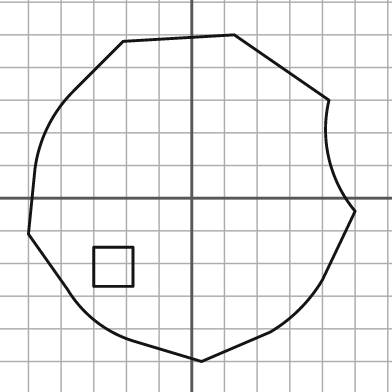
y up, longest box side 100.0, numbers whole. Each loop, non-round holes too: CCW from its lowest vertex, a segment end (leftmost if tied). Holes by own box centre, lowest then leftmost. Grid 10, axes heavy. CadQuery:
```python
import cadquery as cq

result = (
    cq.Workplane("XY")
    .moveTo(3.0, -50.0)
    .lineTo(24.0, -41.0)
    .threePointArc((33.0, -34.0), (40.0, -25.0))
    .lineTo(50.0, -4.0)
    .threePointArc((42.0, 12.0), (42.0, 30.0))
    .lineTo(13.0, 50.0)
    .lineTo(-21.0, 48.0)
    .lineTo(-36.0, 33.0)
    .threePointArc((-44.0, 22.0), (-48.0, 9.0))
    .lineTo(-50.0, -11.0)
    .lineTo(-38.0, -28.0)
    .threePointArc((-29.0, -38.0), (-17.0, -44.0))
    .close()
    .moveTo(-30.0, -27.0)
    .lineTo(-18.0, -27.0)
    .lineTo(-18.0, -15.0)
    .lineTo(-30.0, -15.0)
    .close()
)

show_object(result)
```